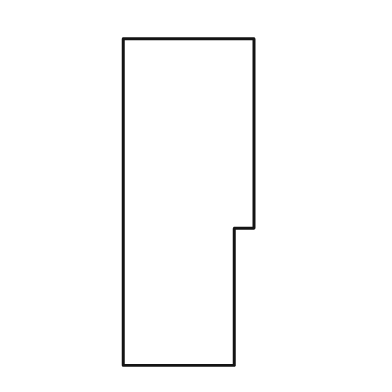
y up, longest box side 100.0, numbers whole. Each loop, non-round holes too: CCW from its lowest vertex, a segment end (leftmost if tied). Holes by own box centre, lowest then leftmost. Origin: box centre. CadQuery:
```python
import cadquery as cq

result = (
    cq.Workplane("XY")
    .moveTo(-20.0, -50.0)
    .lineTo(14.0, -50.0)
    .lineTo(14.0, -8.0)
    .lineTo(20.0, -8.0)
    .lineTo(20.0, 50.0)
    .lineTo(-20.0, 50.0)
    .close()
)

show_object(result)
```